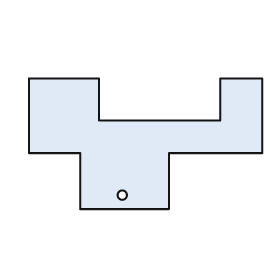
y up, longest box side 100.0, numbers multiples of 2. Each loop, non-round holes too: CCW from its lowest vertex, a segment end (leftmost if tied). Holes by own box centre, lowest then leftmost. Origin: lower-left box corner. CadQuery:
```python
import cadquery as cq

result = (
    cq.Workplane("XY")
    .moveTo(22.0, 0.0)
    .lineTo(60.0, 0.0)
    .lineTo(60.0, 24.0)
    .lineTo(100.0, 24.0)
    .lineTo(100.0, 56.0)
    .lineTo(82.0, 56.0)
    .lineTo(82.0, 38.0)
    .lineTo(30.0, 38.0)
    .lineTo(30.0, 56.0)
    .lineTo(0.0, 56.0)
    .lineTo(0.0, 24.0)
    .lineTo(22.0, 24.0)
    .close()
    .moveTo(40.0, 6.0)
    .circle(2.0)
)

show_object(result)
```